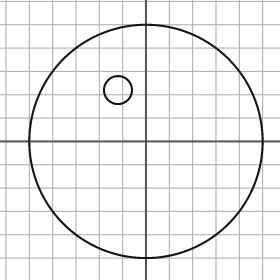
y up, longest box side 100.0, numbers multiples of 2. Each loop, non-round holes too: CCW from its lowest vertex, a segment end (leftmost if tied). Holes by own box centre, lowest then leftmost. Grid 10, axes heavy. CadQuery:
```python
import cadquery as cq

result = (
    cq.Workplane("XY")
    .moveTo(0.0, 0.0)
    .circle(50.0)
    .moveTo(-12.0, 22.0)
    .circle(6.0)
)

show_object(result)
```